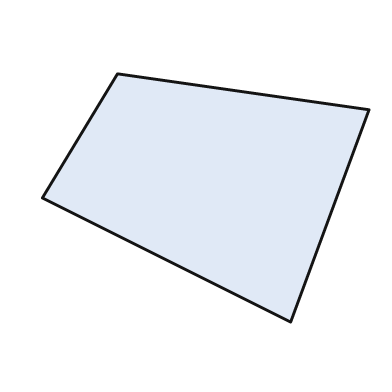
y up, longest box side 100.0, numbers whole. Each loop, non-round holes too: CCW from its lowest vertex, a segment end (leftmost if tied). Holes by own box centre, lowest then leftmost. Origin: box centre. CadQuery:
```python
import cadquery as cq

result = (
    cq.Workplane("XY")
    .moveTo(26.0, -38.0)
    .lineTo(50.0, 27.0)
    .lineTo(-27.0, 38.0)
    .lineTo(-50.0, 0.0)
    .close()
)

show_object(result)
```